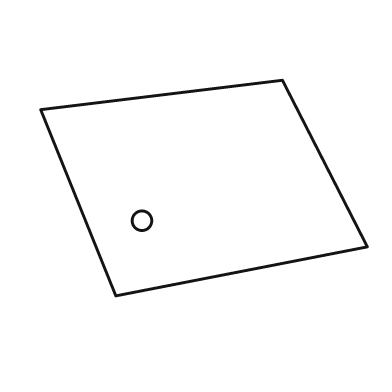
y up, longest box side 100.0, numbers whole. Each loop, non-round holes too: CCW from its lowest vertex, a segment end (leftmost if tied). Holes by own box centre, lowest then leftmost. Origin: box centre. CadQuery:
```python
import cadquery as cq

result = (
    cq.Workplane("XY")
    .moveTo(-27.0, -33.0)
    .lineTo(50.0, -18.0)
    .lineTo(24.0, 33.0)
    .lineTo(-50.0, 24.0)
    .close()
    .moveTo(-19.0, -10.0)
    .circle(3.0)
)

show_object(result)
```